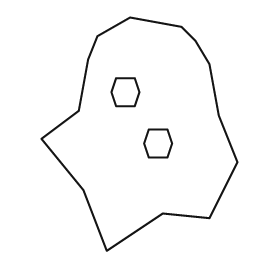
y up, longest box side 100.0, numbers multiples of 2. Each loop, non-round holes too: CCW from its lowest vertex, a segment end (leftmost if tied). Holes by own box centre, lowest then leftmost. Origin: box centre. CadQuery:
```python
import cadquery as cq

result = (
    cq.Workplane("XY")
    .moveTo(-14.0, -50.0)
    .lineTo(10.0, -34.0)
    .lineTo(30.0, -36.0)
    .lineTo(42.0, -12.0)
    .lineTo(34.0, 8.0)
    .lineTo(30.0, 30.0)
    .lineTo(24.0, 40.0)
    .lineTo(18.0, 46.0)
    .lineTo(-4.0, 50.0)
    .lineTo(-18.0, 42.0)
    .lineTo(-22.0, 32.0)
    .lineTo(-26.0, 10.0)
    .lineTo(-42.0, -2.0)
    .lineTo(-24.0, -24.0)
    .close()
    .moveTo(4.0, -10.0)
    .lineTo(12.0, -10.0)
    .lineTo(14.0, -4.0)
    .lineTo(12.0, 2.0)
    .lineTo(4.0, 2.0)
    .lineTo(2.0, -4.0)
    .close()
    .moveTo(-10.0, 12.0)
    .lineTo(-2.0, 12.0)
    .lineTo(0.0, 18.0)
    .lineTo(-2.0, 24.0)
    .lineTo(-10.0, 24.0)
    .lineTo(-12.0, 18.0)
    .close()
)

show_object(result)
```